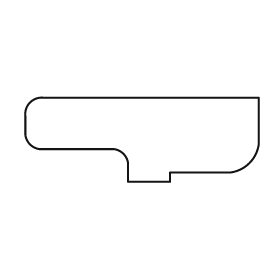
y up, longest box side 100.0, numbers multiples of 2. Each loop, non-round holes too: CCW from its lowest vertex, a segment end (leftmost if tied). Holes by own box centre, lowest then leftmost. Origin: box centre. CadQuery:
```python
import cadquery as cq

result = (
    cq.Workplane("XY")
    .moveTo(-6.0, -18.0)
    .lineTo(12.0, -18.0)
    .lineTo(12.0, -14.0)
    .lineTo(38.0, -14.0)
    .threePointArc((46.0, -10.0), (50.0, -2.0))
    .lineTo(50.0, 18.0)
    .lineTo(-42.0, 18.0)
    .threePointArc((-48.0, 16.0), (-50.0, 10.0))
    .lineTo(-50.0, 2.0)
    .threePointArc((-48.0, -2.0), (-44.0, -4.0))
    .lineTo(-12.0, -4.0)
    .threePointArc((-8.0, -6.0), (-6.0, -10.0))
    .close()
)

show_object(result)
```